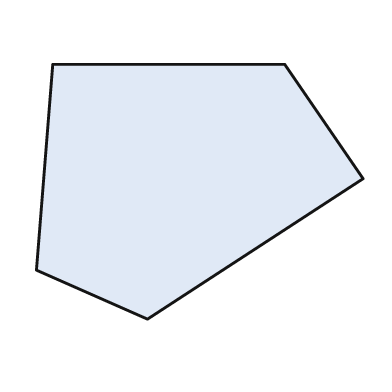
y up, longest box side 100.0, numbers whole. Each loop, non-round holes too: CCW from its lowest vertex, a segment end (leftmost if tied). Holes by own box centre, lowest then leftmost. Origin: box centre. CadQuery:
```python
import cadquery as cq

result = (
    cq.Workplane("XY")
    .moveTo(-16.0, -39.0)
    .lineTo(50.0, 4.0)
    .lineTo(26.0, 39.0)
    .lineTo(-45.0, 39.0)
    .lineTo(-50.0, -24.0)
    .close()
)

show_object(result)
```